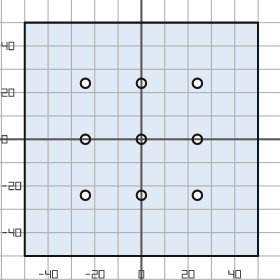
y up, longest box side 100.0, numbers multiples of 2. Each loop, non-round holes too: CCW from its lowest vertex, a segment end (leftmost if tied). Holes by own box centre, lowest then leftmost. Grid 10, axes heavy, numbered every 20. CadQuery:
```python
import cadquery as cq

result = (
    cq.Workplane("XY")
    .moveTo(-50.0, -50.0)
    .lineTo(50.0, -50.0)
    .lineTo(50.0, 50.0)
    .lineTo(-50.0, 50.0)
    .close()
    .moveTo(-24.0, -24.0)
    .circle(2.0)
    .moveTo(0.0, -24.0)
    .circle(2.0)
    .moveTo(24.0, -24.0)
    .circle(2.0)
    .moveTo(-24.0, 0.0)
    .circle(2.0)
    .moveTo(0.0, 0.0)
    .circle(2.0)
    .moveTo(24.0, 0.0)
    .circle(2.0)
    .moveTo(-24.0, 24.0)
    .circle(2.0)
    .moveTo(0.0, 24.0)
    .circle(2.0)
    .moveTo(24.0, 24.0)
    .circle(2.0)
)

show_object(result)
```